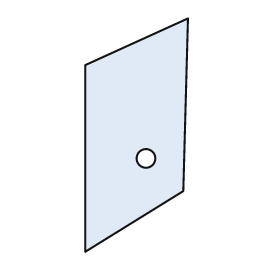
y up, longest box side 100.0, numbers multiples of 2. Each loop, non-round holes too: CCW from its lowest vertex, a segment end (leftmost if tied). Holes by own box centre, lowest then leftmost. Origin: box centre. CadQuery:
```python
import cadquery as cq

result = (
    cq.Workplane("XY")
    .moveTo(-22.0, -50.0)
    .lineTo(20.0, -24.0)
    .lineTo(22.0, 50.0)
    .lineTo(-22.0, 30.0)
    .close()
    .moveTo(4.0, -10.0)
    .circle(4.0)
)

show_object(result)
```